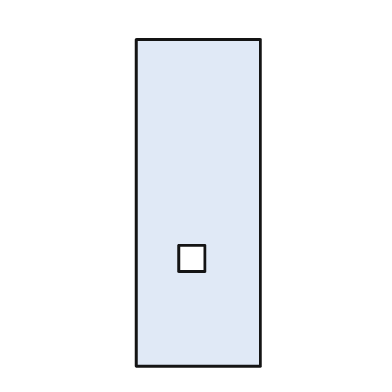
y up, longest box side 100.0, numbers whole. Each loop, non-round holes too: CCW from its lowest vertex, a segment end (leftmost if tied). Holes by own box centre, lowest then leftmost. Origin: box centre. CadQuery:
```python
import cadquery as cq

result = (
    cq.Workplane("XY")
    .moveTo(-19.0, -50.0)
    .lineTo(19.0, -50.0)
    .lineTo(19.0, 50.0)
    .lineTo(-19.0, 50.0)
    .close()
    .moveTo(-6.0, -21.0)
    .lineTo(2.0, -21.0)
    .lineTo(2.0, -13.0)
    .lineTo(-6.0, -13.0)
    .close()
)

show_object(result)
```